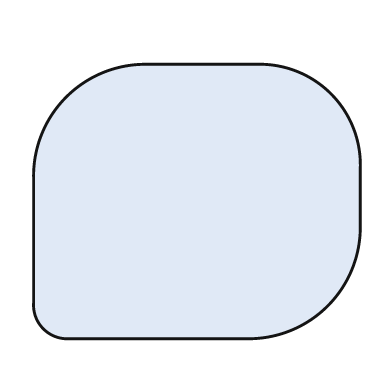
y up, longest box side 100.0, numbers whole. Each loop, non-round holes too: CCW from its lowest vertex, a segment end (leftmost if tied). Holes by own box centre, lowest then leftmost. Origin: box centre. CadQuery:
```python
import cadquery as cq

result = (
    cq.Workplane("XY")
    .moveTo(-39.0, -42.0)
    .lineTo(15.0, -42.0)
    .threePointArc((40.0, -32.0), (50.0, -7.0))
    .lineTo(50.0, 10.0)
    .threePointArc((41.0, 33.0), (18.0, 42.0))
    .lineTo(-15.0, 42.0)
    .threePointArc((-40.0, 32.0), (-50.0, 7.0))
    .lineTo(-50.0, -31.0)
    .threePointArc((-47.0, -39.0), (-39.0, -42.0))
    .close()
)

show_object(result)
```